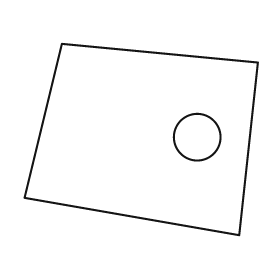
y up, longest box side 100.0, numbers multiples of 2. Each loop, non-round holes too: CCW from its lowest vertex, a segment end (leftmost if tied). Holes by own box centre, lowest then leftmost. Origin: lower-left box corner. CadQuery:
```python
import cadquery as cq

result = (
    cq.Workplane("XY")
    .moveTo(92.0, 0.0)
    .lineTo(100.0, 74.0)
    .lineTo(16.0, 82.0)
    .lineTo(0.0, 16.0)
    .close()
    .moveTo(74.0, 42.0)
    .circle(10.0)
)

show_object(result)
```